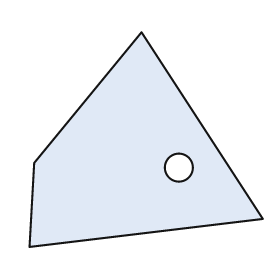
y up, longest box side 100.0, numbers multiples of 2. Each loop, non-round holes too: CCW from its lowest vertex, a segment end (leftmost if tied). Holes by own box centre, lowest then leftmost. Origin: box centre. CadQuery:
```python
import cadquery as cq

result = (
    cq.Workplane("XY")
    .moveTo(-50.0, -46.0)
    .lineTo(50.0, -34.0)
    .lineTo(-2.0, 46.0)
    .lineTo(-48.0, -10.0)
    .close()
    .moveTo(14.0, -12.0)
    .circle(6.0)
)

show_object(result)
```